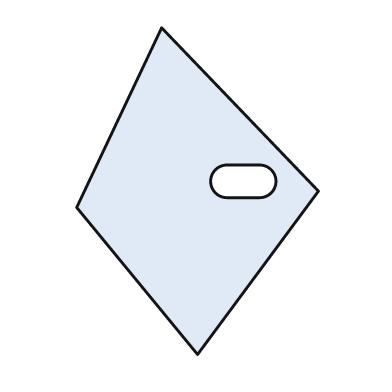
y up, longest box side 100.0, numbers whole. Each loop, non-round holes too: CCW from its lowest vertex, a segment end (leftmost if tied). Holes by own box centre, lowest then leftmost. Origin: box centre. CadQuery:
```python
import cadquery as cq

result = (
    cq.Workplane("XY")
    .moveTo(0.0, -50.0)
    .lineTo(37.0, 0.0)
    .lineTo(-11.0, 50.0)
    .lineTo(-37.0, -5.0)
    .close()
    .moveTo(9.0, -2.0)
    .lineTo(19.0, -2.0)
    .threePointArc((24.0, 3.0), (19.0, 8.0))
    .lineTo(9.0, 8.0)
    .threePointArc((4.0, 3.0), (9.0, -2.0))
    .close()
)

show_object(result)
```